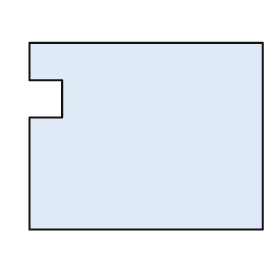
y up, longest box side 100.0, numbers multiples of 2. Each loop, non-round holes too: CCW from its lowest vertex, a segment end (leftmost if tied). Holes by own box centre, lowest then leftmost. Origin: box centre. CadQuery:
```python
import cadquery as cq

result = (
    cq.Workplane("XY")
    .moveTo(-50.0, -40.0)
    .lineTo(50.0, -40.0)
    .lineTo(50.0, 40.0)
    .lineTo(-50.0, 40.0)
    .lineTo(-50.0, 24.0)
    .lineTo(-36.0, 24.0)
    .lineTo(-36.0, 8.0)
    .lineTo(-50.0, 8.0)
    .close()
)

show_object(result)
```